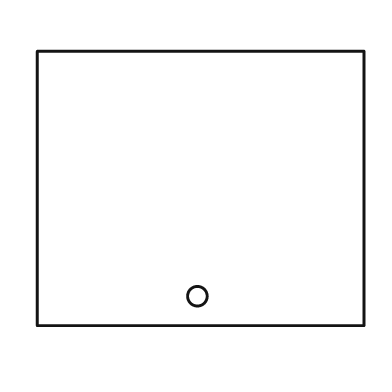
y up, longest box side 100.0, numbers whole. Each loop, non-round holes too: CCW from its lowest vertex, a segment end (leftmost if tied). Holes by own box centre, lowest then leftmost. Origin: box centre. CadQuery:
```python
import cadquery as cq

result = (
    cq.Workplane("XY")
    .moveTo(-50.0, -42.0)
    .lineTo(50.0, -42.0)
    .lineTo(50.0, 42.0)
    .lineTo(-50.0, 42.0)
    .close()
    .moveTo(-1.0, -33.0)
    .circle(3.0)
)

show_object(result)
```